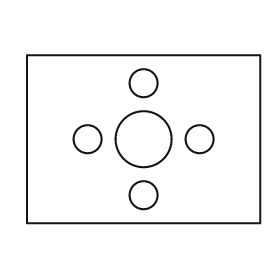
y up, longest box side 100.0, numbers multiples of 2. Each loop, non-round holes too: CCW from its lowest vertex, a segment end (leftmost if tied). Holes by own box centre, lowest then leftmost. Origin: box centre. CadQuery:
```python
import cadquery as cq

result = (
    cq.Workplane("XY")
    .moveTo(-50.0, -36.0)
    .lineTo(50.0, -36.0)
    .lineTo(50.0, 36.0)
    .lineTo(-50.0, 36.0)
    .close()
    .moveTo(0.0, -24.0)
    .circle(6.0)
    .moveTo(-24.0, 0.0)
    .circle(6.0)
    .moveTo(0.0, 0.0)
    .circle(12.0)
    .moveTo(24.0, 0.0)
    .circle(6.0)
    .moveTo(0.0, 24.0)
    .circle(6.0)
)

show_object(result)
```